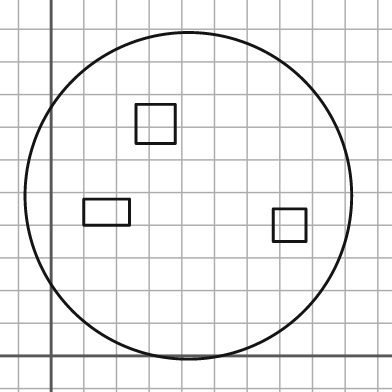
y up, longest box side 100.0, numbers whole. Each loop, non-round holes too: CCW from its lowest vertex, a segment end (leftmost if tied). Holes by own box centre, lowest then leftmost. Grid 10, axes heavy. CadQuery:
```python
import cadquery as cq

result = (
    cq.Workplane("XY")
    .moveTo(42.0, 49.0)
    .circle(50.0)
    .moveTo(68.0, 35.0)
    .lineTo(78.0, 35.0)
    .lineTo(78.0, 45.0)
    .lineTo(68.0, 45.0)
    .close()
    .moveTo(10.0, 40.0)
    .lineTo(24.0, 40.0)
    .lineTo(24.0, 48.0)
    .lineTo(10.0, 48.0)
    .close()
    .moveTo(26.0, 65.0)
    .lineTo(38.0, 65.0)
    .lineTo(38.0, 77.0)
    .lineTo(26.0, 77.0)
    .close()
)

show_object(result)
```